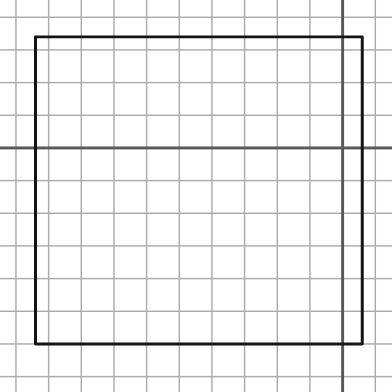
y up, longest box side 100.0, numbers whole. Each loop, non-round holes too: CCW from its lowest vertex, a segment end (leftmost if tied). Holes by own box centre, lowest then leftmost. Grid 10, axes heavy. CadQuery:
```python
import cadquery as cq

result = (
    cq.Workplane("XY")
    .moveTo(-94.0, -60.0)
    .lineTo(6.0, -60.0)
    .lineTo(6.0, 34.0)
    .lineTo(-94.0, 34.0)
    .close()
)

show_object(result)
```